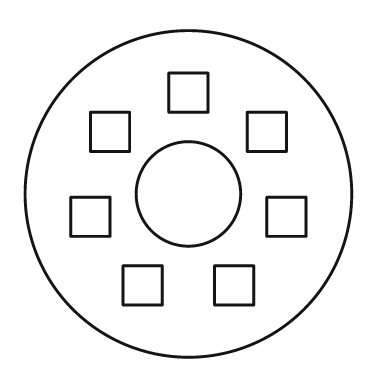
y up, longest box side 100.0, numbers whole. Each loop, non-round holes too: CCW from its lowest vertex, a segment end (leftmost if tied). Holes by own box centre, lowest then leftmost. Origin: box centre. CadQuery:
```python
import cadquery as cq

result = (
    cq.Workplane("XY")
    .moveTo(0.0, 0.0)
    .circle(50.0)
    .moveTo(-20.0, -34.0)
    .lineTo(-8.0, -34.0)
    .lineTo(-8.0, -22.0)
    .lineTo(-20.0, -22.0)
    .close()
    .moveTo(8.0, -34.0)
    .lineTo(20.0, -34.0)
    .lineTo(20.0, -22.0)
    .lineTo(8.0, -22.0)
    .close()
    .moveTo(-36.0, -13.0)
    .lineTo(-24.0, -13.0)
    .lineTo(-24.0, -1.0)
    .lineTo(-36.0, -1.0)
    .close()
    .moveTo(24.0, -13.0)
    .lineTo(36.0, -13.0)
    .lineTo(36.0, -1.0)
    .lineTo(24.0, -1.0)
    .close()
    .moveTo(0.0, 0.0)
    .circle(16.0)
    .moveTo(-30.0, 13.0)
    .lineTo(-18.0, 13.0)
    .lineTo(-18.0, 25.0)
    .lineTo(-30.0, 25.0)
    .close()
    .moveTo(18.0, 13.0)
    .lineTo(30.0, 13.0)
    .lineTo(30.0, 25.0)
    .lineTo(18.0, 25.0)
    .close()
    .moveTo(-6.0, 25.0)
    .lineTo(6.0, 25.0)
    .lineTo(6.0, 37.0)
    .lineTo(-6.0, 37.0)
    .close()
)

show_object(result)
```